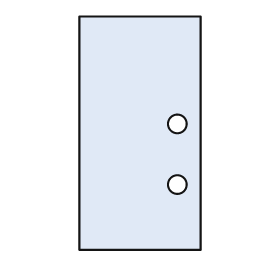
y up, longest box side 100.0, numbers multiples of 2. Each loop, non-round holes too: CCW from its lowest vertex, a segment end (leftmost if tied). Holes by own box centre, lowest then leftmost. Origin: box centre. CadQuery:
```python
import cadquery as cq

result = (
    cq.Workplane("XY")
    .moveTo(-26.0, -50.0)
    .lineTo(26.0, -50.0)
    .lineTo(26.0, 50.0)
    .lineTo(-26.0, 50.0)
    .close()
    .moveTo(16.0, -22.0)
    .circle(4.0)
    .moveTo(16.0, 4.0)
    .circle(4.0)
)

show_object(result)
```